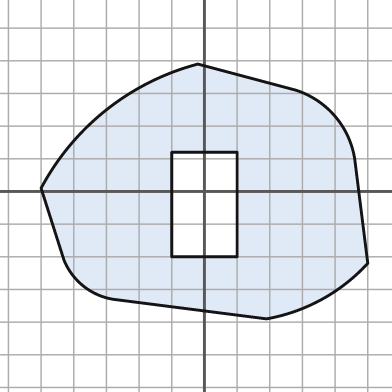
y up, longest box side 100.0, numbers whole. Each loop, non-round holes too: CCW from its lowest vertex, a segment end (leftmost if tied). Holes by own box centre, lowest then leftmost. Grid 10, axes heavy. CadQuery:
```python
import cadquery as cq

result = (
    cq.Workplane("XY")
    .moveTo(19.0, -39.0)
    .threePointArc((36.0, -33.0), (50.0, -22.0))
    .lineTo(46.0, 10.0)
    .threePointArc((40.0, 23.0), (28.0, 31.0))
    .lineTo(-2.0, 39.0)
    .threePointArc((-30.0, 25.0), (-50.0, 1.0))
    .lineTo(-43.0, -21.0)
    .threePointArc((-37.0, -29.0), (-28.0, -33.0))
    .close()
    .moveTo(-10.0, -20.0)
    .lineTo(10.0, -20.0)
    .lineTo(10.0, 12.0)
    .lineTo(-10.0, 12.0)
    .close()
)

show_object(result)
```